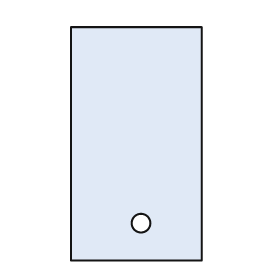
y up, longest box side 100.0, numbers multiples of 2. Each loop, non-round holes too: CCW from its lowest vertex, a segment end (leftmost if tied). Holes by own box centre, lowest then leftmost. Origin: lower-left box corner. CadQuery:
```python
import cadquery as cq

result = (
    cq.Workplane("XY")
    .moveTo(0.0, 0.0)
    .lineTo(56.0, 0.0)
    .lineTo(56.0, 100.0)
    .lineTo(0.0, 100.0)
    .close()
    .moveTo(30.0, 16.0)
    .circle(4.0)
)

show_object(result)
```